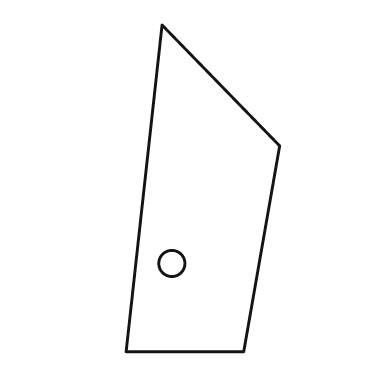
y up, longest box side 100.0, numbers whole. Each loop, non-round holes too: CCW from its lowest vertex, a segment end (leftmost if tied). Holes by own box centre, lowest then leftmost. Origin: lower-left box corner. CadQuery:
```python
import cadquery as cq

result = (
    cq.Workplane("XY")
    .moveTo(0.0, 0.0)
    .lineTo(36.0, 0.0)
    .lineTo(47.0, 63.0)
    .lineTo(11.0, 100.0)
    .close()
    .moveTo(14.0, 27.0)
    .circle(4.0)
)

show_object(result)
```